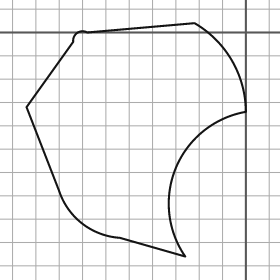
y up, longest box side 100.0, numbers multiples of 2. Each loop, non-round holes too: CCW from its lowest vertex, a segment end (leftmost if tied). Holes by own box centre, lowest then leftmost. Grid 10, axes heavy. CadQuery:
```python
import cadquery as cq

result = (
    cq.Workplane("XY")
    .moveTo(-26.0, -96.0)
    .threePointArc((-30.0, -58.0), (0.0, -34.0))
    .threePointArc((-6.0, -12.0), (-22.0, 4.0))
    .lineTo(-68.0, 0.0)
    .threePointArc((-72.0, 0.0), (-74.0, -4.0))
    .lineTo(-94.0, -32.0)
    .lineTo(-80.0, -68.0)
    .threePointArc((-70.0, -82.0), (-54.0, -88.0))
    .close()
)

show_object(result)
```